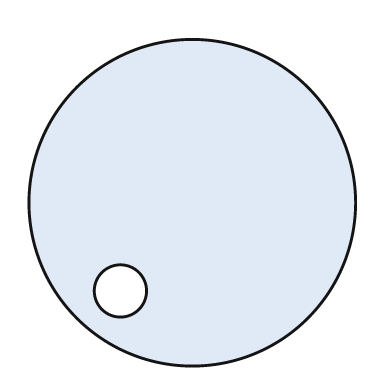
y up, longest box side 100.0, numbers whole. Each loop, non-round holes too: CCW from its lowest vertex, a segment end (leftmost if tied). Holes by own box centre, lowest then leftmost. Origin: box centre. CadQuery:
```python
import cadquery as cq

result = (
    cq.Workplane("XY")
    .moveTo(0.0, 0.0)
    .circle(50.0)
    .moveTo(-22.0, -27.0)
    .circle(8.0)
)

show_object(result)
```